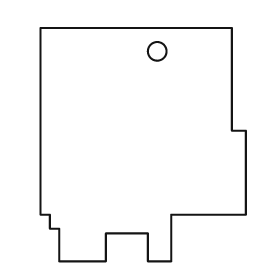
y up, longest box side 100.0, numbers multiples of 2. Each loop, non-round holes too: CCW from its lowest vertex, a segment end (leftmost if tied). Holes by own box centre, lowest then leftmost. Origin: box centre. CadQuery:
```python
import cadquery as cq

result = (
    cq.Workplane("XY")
    .moveTo(-36.0, -50.0)
    .lineTo(-16.0, -50.0)
    .lineTo(-16.0, -38.0)
    .lineTo(2.0, -38.0)
    .lineTo(2.0, -50.0)
    .lineTo(12.0, -50.0)
    .lineTo(12.0, -30.0)
    .lineTo(44.0, -30.0)
    .lineTo(44.0, 6.0)
    .lineTo(38.0, 6.0)
    .lineTo(38.0, 50.0)
    .lineTo(-44.0, 50.0)
    .lineTo(-44.0, -30.0)
    .lineTo(-40.0, -30.0)
    .lineTo(-40.0, -36.0)
    .lineTo(-36.0, -36.0)
    .close()
    .moveTo(6.0, 40.0)
    .circle(4.0)
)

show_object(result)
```